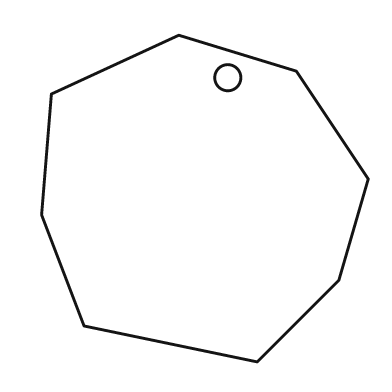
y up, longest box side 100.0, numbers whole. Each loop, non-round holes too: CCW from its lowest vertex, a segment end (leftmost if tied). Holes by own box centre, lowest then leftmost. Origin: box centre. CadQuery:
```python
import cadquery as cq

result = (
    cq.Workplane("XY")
    .moveTo(16.0, -50.0)
    .lineTo(41.0, -25.0)
    .lineTo(50.0, 6.0)
    .lineTo(28.0, 39.0)
    .lineTo(-8.0, 50.0)
    .lineTo(-47.0, 32.0)
    .lineTo(-50.0, -5.0)
    .lineTo(-37.0, -39.0)
    .close()
    .moveTo(7.0, 37.0)
    .circle(4.0)
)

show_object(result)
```